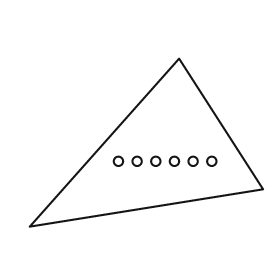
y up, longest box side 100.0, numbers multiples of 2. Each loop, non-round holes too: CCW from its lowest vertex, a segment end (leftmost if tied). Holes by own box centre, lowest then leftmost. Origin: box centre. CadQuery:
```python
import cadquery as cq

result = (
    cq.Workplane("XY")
    .moveTo(-50.0, -36.0)
    .lineTo(50.0, -20.0)
    .lineTo(14.0, 36.0)
    .close()
    .moveTo(-12.0, -8.0)
    .circle(2.0)
    .moveTo(-4.0, -8.0)
    .circle(2.0)
    .moveTo(4.0, -8.0)
    .circle(2.0)
    .moveTo(12.0, -8.0)
    .circle(2.0)
    .moveTo(20.0, -8.0)
    .circle(2.0)
    .moveTo(28.0, -8.0)
    .circle(2.0)
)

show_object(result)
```